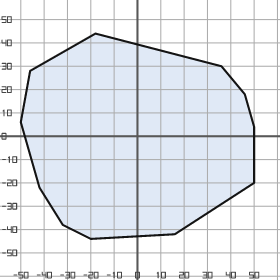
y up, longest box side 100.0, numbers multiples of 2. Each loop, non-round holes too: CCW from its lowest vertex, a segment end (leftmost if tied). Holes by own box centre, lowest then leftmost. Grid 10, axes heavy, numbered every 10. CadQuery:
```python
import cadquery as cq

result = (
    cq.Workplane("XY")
    .moveTo(-20.0, -44.0)
    .lineTo(16.0, -42.0)
    .lineTo(50.0, -20.0)
    .lineTo(50.0, 4.0)
    .lineTo(46.0, 18.0)
    .lineTo(36.0, 30.0)
    .lineTo(-18.0, 44.0)
    .lineTo(-46.0, 28.0)
    .lineTo(-50.0, 6.0)
    .lineTo(-42.0, -22.0)
    .lineTo(-32.0, -38.0)
    .close()
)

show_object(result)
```